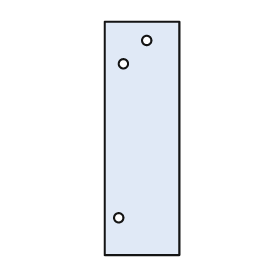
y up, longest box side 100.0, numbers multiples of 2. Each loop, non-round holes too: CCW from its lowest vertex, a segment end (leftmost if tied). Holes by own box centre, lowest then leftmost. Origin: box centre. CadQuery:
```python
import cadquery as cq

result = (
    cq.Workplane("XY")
    .moveTo(-16.0, -50.0)
    .lineTo(16.0, -50.0)
    .lineTo(16.0, 50.0)
    .lineTo(-16.0, 50.0)
    .close()
    .moveTo(-10.0, -34.0)
    .circle(2.0)
    .moveTo(-8.0, 32.0)
    .circle(2.0)
    .moveTo(2.0, 42.0)
    .circle(2.0)
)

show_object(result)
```